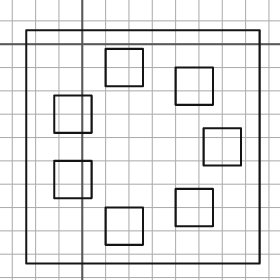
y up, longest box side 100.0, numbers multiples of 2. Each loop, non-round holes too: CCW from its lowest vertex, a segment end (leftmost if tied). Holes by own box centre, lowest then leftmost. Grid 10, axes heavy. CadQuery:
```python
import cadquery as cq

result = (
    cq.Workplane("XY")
    .moveTo(-24.0, -94.0)
    .lineTo(76.0, -94.0)
    .lineTo(76.0, 6.0)
    .lineTo(-24.0, 6.0)
    .close()
    .moveTo(10.0, -86.0)
    .lineTo(26.0, -86.0)
    .lineTo(26.0, -70.0)
    .lineTo(10.0, -70.0)
    .close()
    .moveTo(40.0, -78.0)
    .lineTo(56.0, -78.0)
    .lineTo(56.0, -62.0)
    .lineTo(40.0, -62.0)
    .close()
    .moveTo(-12.0, -66.0)
    .lineTo(4.0, -66.0)
    .lineTo(4.0, -50.0)
    .lineTo(-12.0, -50.0)
    .close()
    .moveTo(52.0, -52.0)
    .lineTo(68.0, -52.0)
    .lineTo(68.0, -36.0)
    .lineTo(52.0, -36.0)
    .close()
    .moveTo(-12.0, -38.0)
    .lineTo(4.0, -38.0)
    .lineTo(4.0, -22.0)
    .lineTo(-12.0, -22.0)
    .close()
    .moveTo(40.0, -26.0)
    .lineTo(56.0, -26.0)
    .lineTo(56.0, -10.0)
    .lineTo(40.0, -10.0)
    .close()
    .moveTo(10.0, -18.0)
    .lineTo(26.0, -18.0)
    .lineTo(26.0, -2.0)
    .lineTo(10.0, -2.0)
    .close()
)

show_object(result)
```